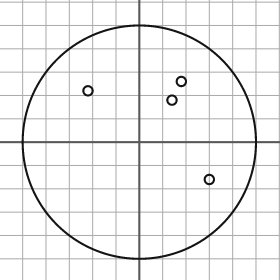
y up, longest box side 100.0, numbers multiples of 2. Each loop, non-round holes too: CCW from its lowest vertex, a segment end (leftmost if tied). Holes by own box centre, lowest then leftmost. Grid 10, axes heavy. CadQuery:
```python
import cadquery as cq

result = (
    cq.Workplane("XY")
    .moveTo(0.0, 0.0)
    .circle(50.0)
    .moveTo(30.0, -16.0)
    .circle(2.0)
    .moveTo(14.0, 18.0)
    .circle(2.0)
    .moveTo(-22.0, 22.0)
    .circle(2.0)
    .moveTo(18.0, 26.0)
    .circle(2.0)
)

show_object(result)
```